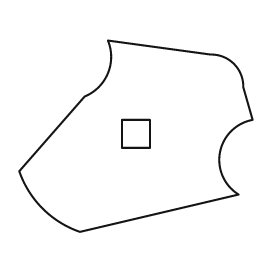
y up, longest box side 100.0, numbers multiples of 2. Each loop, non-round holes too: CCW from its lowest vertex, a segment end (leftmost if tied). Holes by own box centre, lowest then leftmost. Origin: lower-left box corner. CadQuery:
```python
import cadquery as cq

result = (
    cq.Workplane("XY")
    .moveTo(26.0, 0.0)
    .lineTo(94.0, 16.0)
    .threePointArc((86.0, 34.0), (100.0, 48.0))
    .lineTo(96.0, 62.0)
    .threePointArc((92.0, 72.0), (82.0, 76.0))
    .lineTo(38.0, 82.0)
    .threePointArc((38.0, 68.0), (28.0, 58.0))
    .lineTo(0.0, 26.0)
    .threePointArc((10.0, 10.0), (26.0, 0.0))
    .close()
    .moveTo(44.0, 36.0)
    .lineTo(56.0, 36.0)
    .lineTo(56.0, 48.0)
    .lineTo(44.0, 48.0)
    .close()
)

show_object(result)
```